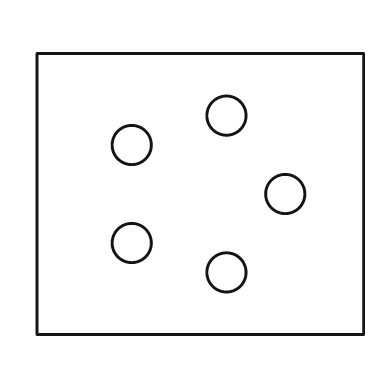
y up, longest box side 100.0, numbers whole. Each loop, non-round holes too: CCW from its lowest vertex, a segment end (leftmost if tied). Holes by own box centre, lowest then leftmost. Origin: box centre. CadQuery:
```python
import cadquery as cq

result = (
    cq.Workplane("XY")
    .moveTo(-50.0, -43.0)
    .lineTo(50.0, -43.0)
    .lineTo(50.0, 43.0)
    .lineTo(-50.0, 43.0)
    .close()
    .moveTo(8.0, -24.0)
    .circle(6.0)
    .moveTo(-21.0, -15.0)
    .circle(6.0)
    .moveTo(26.0, 0.0)
    .circle(6.0)
    .moveTo(-21.0, 15.0)
    .circle(6.0)
    .moveTo(8.0, 24.0)
    .circle(6.0)
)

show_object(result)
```